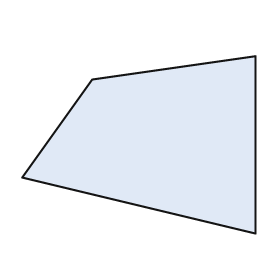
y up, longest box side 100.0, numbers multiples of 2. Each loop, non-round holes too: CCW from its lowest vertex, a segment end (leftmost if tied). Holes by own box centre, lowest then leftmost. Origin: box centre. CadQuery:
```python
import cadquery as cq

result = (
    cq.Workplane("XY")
    .moveTo(50.0, -38.0)
    .lineTo(50.0, 38.0)
    .lineTo(-20.0, 28.0)
    .lineTo(-50.0, -14.0)
    .close()
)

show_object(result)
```